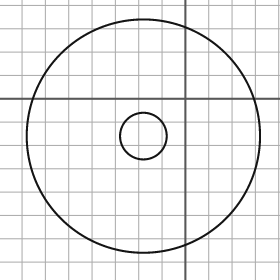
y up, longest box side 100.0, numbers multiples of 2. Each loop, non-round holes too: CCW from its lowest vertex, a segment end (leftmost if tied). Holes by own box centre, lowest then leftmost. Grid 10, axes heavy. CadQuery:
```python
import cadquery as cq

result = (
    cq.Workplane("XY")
    .moveTo(-18.0, -16.0)
    .circle(50.0)
    .moveTo(-18.0, -16.0)
    .circle(10.0)
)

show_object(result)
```